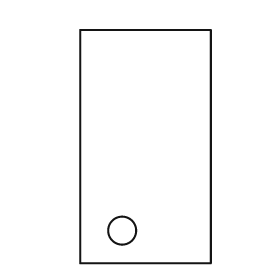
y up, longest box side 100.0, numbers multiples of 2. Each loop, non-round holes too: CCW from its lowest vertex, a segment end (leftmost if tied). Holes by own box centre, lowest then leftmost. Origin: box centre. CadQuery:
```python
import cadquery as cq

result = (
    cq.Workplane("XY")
    .moveTo(-28.0, -50.0)
    .lineTo(28.0, -50.0)
    .lineTo(28.0, 50.0)
    .lineTo(-28.0, 50.0)
    .close()
    .moveTo(-10.0, -36.0)
    .circle(6.0)
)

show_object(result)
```